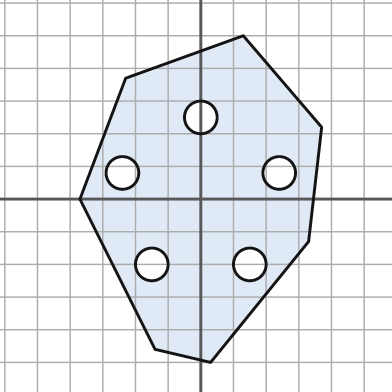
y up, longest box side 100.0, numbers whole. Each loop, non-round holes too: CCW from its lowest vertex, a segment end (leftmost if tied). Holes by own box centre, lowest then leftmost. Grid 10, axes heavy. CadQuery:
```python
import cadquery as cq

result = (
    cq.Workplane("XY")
    .moveTo(3.0, -50.0)
    .lineTo(33.0, -13.0)
    .lineTo(37.0, 22.0)
    .lineTo(13.0, 50.0)
    .lineTo(-23.0, 37.0)
    .lineTo(-37.0, 0.0)
    .lineTo(-14.0, -46.0)
    .close()
    .moveTo(-15.0, -20.0)
    .circle(5.0)
    .moveTo(15.0, -20.0)
    .circle(5.0)
    .moveTo(-24.0, 8.0)
    .circle(5.0)
    .moveTo(24.0, 8.0)
    .circle(5.0)
    .moveTo(0.0, 25.0)
    .circle(5.0)
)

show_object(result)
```